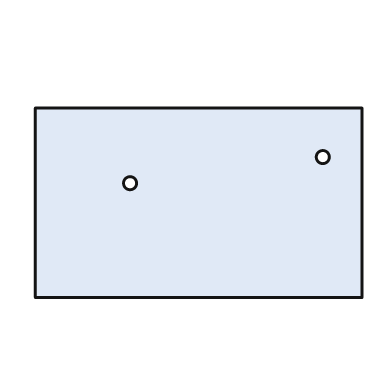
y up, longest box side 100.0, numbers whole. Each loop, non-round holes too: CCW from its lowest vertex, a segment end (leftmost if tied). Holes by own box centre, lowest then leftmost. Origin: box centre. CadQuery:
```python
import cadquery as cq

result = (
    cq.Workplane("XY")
    .moveTo(-50.0, -29.0)
    .lineTo(50.0, -29.0)
    .lineTo(50.0, 29.0)
    .lineTo(-50.0, 29.0)
    .close()
    .moveTo(-21.0, 6.0)
    .circle(2.0)
    .moveTo(38.0, 14.0)
    .circle(2.0)
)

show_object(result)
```